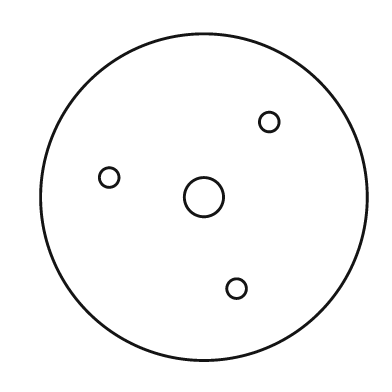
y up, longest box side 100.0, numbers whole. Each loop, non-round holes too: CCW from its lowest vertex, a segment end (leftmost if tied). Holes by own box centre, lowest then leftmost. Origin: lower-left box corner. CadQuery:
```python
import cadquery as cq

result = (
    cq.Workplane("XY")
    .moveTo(50.0, 50.0)
    .circle(50.0)
    .moveTo(60.0, 22.0)
    .circle(3.0)
    .moveTo(50.0, 50.0)
    .circle(6.0)
    .moveTo(21.0, 56.0)
    .circle(3.0)
    .moveTo(70.0, 73.0)
    .circle(3.0)
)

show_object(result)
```